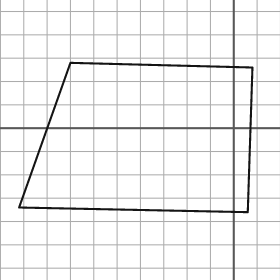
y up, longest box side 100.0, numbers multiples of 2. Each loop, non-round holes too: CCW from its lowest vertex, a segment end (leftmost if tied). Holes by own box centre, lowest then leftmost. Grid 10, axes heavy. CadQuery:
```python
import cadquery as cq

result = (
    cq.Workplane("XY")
    .moveTo(6.0, -36.0)
    .lineTo(8.0, 26.0)
    .lineTo(-70.0, 28.0)
    .lineTo(-92.0, -34.0)
    .close()
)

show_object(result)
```